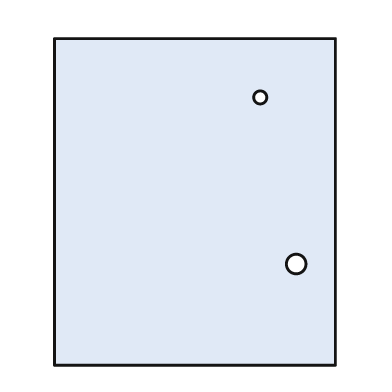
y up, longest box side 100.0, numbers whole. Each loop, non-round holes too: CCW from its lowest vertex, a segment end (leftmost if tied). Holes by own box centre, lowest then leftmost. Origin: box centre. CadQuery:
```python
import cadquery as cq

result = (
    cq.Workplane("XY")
    .moveTo(-43.0, -50.0)
    .lineTo(43.0, -50.0)
    .lineTo(43.0, 50.0)
    .lineTo(-43.0, 50.0)
    .close()
    .moveTo(31.0, -19.0)
    .circle(3.0)
    .moveTo(20.0, 32.0)
    .circle(2.0)
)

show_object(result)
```